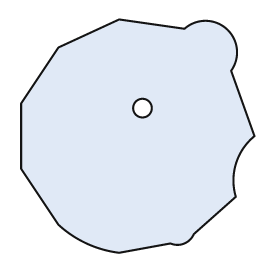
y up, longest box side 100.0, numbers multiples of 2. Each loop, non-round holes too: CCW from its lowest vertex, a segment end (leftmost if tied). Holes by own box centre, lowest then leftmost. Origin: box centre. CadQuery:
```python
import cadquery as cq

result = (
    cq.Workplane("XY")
    .moveTo(-8.0, -50.0)
    .lineTo(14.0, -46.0)
    .threePointArc((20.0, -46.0), (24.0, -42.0))
    .lineTo(42.0, -26.0)
    .threePointArc((42.0, -12.0), (50.0, 0.0))
    .lineTo(40.0, 28.0)
    .threePointArc((38.0, 46.0), (20.0, 46.0))
    .lineTo(-8.0, 50.0)
    .lineTo(-34.0, 38.0)
    .lineTo(-50.0, 14.0)
    .lineTo(-50.0, -14.0)
    .lineTo(-34.0, -38.0)
    .threePointArc((-22.0, -46.0), (-8.0, -50.0))
    .close()
    .moveTo(2.0, 12.0)
    .circle(4.0)
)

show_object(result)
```